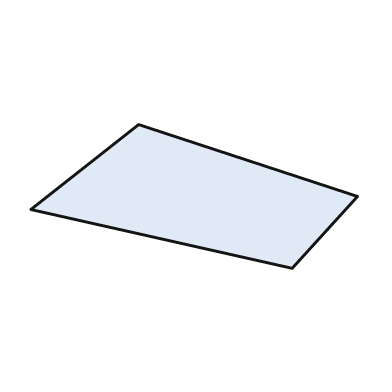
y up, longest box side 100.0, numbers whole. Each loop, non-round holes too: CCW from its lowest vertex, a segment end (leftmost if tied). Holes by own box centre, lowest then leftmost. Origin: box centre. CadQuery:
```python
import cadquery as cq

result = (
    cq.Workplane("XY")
    .moveTo(30.0, -22.0)
    .lineTo(50.0, 0.0)
    .lineTo(-17.0, 22.0)
    .lineTo(-50.0, -4.0)
    .close()
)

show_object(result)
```